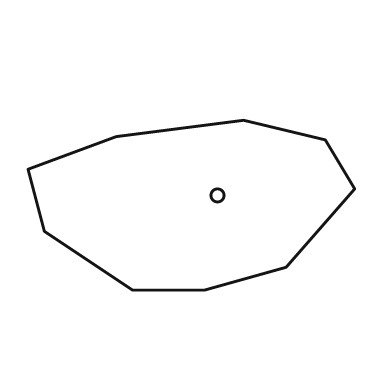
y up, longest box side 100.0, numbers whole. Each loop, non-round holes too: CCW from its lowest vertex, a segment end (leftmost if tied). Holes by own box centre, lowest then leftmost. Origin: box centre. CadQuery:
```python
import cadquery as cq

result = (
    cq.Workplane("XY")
    .moveTo(-18.0, -26.0)
    .lineTo(4.0, -26.0)
    .lineTo(29.0, -19.0)
    .lineTo(50.0, 5.0)
    .lineTo(41.0, 20.0)
    .lineTo(16.0, 26.0)
    .lineTo(-23.0, 21.0)
    .lineTo(-50.0, 11.0)
    .lineTo(-45.0, -8.0)
    .close()
    .moveTo(8.0, 3.0)
    .circle(2.0)
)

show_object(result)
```